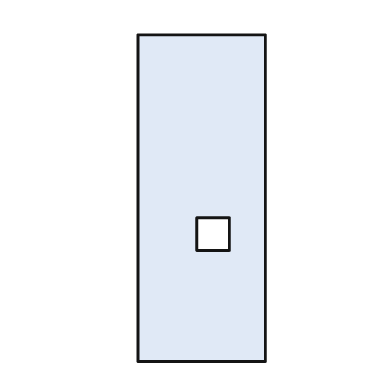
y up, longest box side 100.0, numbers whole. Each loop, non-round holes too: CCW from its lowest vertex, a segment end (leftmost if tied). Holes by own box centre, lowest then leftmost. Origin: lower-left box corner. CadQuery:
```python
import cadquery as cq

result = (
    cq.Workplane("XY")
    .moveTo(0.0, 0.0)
    .lineTo(39.0, 0.0)
    .lineTo(39.0, 100.0)
    .lineTo(0.0, 100.0)
    .close()
    .moveTo(18.0, 34.0)
    .lineTo(28.0, 34.0)
    .lineTo(28.0, 44.0)
    .lineTo(18.0, 44.0)
    .close()
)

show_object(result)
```